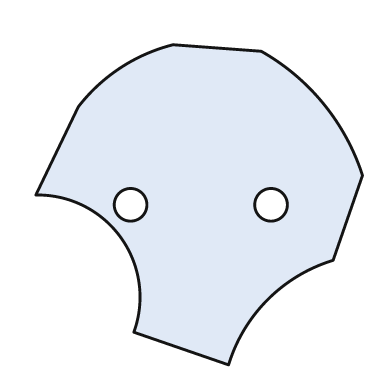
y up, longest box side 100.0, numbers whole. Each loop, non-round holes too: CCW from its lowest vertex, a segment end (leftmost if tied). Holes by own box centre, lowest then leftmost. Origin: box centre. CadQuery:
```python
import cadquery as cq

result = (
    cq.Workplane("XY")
    .moveTo(9.0, -49.0)
    .threePointArc((21.0, -29.0), (41.0, -17.0))
    .lineTo(50.0, 9.0)
    .threePointArc((38.0, 31.0), (19.0, 47.0))
    .lineTo(-8.0, 49.0)
    .threePointArc((-24.0, 42.0), (-37.0, 30.0))
    .lineTo(-50.0, 3.0)
    .threePointArc((-24.0, -10.0), (-20.0, -39.0))
    .close()
    .moveTo(-21.0, 0.0)
    .circle(5.0)
    .moveTo(22.0, 0.0)
    .circle(5.0)
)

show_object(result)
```